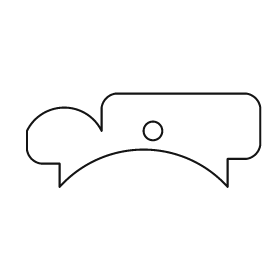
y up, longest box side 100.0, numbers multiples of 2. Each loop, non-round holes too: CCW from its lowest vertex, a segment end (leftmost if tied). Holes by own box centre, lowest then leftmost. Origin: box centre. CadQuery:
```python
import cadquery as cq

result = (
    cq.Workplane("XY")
    .moveTo(-36.0, -20.0)
    .threePointArc((0.0, -4.0), (36.0, -20.0))
    .lineTo(36.0, -8.0)
    .lineTo(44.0, -8.0)
    .threePointArc((48.0, -6.0), (50.0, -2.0))
    .lineTo(50.0, 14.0)
    .threePointArc((48.0, 18.0), (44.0, 20.0))
    .lineTo(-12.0, 20.0)
    .threePointArc((-16.0, 18.0), (-18.0, 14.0))
    .lineTo(-18.0, 4.0)
    .threePointArc((-34.0, 14.0), (-50.0, 4.0))
    .lineTo(-50.0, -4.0)
    .threePointArc((-48.0, -8.0), (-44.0, -10.0))
    .lineTo(-36.0, -10.0)
    .close()
    .moveTo(4.0, 4.0)
    .circle(4.0)
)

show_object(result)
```